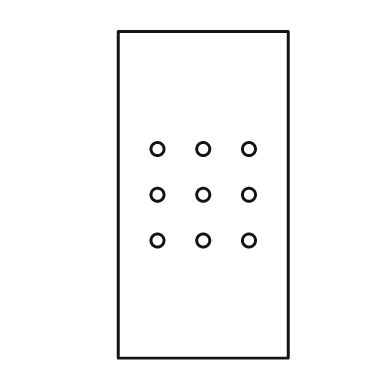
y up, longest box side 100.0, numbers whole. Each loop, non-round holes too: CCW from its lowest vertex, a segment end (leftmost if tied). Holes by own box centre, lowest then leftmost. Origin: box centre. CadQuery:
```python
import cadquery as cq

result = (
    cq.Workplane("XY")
    .moveTo(-26.0, -50.0)
    .lineTo(26.0, -50.0)
    .lineTo(26.0, 50.0)
    .lineTo(-26.0, 50.0)
    .close()
    .moveTo(-14.0, -14.0)
    .circle(2.0)
    .moveTo(0.0, -14.0)
    .circle(2.0)
    .moveTo(14.0, -14.0)
    .circle(2.0)
    .moveTo(-14.0, 0.0)
    .circle(2.0)
    .moveTo(0.0, 0.0)
    .circle(2.0)
    .moveTo(14.0, 0.0)
    .circle(2.0)
    .moveTo(-14.0, 14.0)
    .circle(2.0)
    .moveTo(0.0, 14.0)
    .circle(2.0)
    .moveTo(14.0, 14.0)
    .circle(2.0)
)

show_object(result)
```